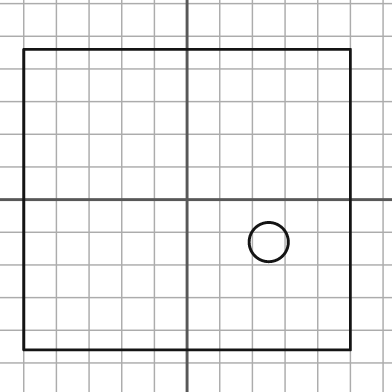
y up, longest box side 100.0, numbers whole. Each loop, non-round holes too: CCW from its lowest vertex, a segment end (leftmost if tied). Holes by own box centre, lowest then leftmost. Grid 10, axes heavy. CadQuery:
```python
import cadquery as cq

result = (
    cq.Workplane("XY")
    .moveTo(-50.0, -46.0)
    .lineTo(50.0, -46.0)
    .lineTo(50.0, 46.0)
    .lineTo(-50.0, 46.0)
    .close()
    .moveTo(25.0, -13.0)
    .circle(6.0)
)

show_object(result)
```